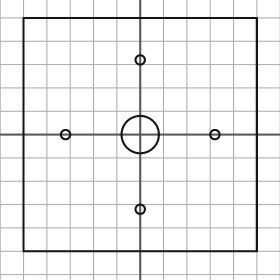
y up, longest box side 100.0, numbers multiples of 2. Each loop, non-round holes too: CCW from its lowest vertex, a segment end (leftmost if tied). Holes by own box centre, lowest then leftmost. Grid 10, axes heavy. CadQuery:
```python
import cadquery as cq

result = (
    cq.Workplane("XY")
    .moveTo(-50.0, -50.0)
    .lineTo(50.0, -50.0)
    .lineTo(50.0, 50.0)
    .lineTo(-50.0, 50.0)
    .close()
    .moveTo(0.0, -32.0)
    .circle(2.0)
    .moveTo(-32.0, 0.0)
    .circle(2.0)
    .moveTo(0.0, 0.0)
    .circle(8.0)
    .moveTo(32.0, 0.0)
    .circle(2.0)
    .moveTo(0.0, 32.0)
    .circle(2.0)
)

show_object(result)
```